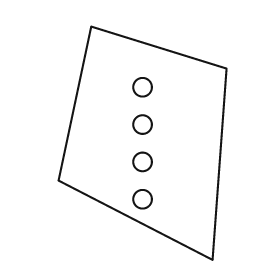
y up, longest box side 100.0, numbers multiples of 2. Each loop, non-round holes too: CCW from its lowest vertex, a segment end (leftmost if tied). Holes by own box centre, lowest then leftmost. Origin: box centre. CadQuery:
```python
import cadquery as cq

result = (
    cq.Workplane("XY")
    .moveTo(30.0, -50.0)
    .lineTo(36.0, 32.0)
    .lineTo(-22.0, 50.0)
    .lineTo(-36.0, -16.0)
    .close()
    .moveTo(0.0, -24.0)
    .circle(4.0)
    .moveTo(0.0, -8.0)
    .circle(4.0)
    .moveTo(0.0, 8.0)
    .circle(4.0)
    .moveTo(0.0, 24.0)
    .circle(4.0)
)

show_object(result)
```